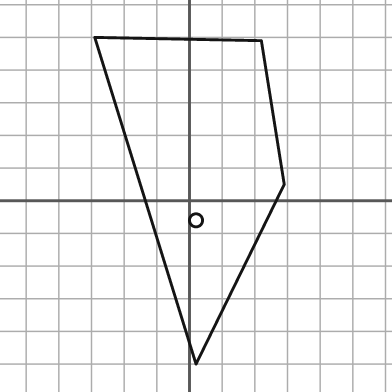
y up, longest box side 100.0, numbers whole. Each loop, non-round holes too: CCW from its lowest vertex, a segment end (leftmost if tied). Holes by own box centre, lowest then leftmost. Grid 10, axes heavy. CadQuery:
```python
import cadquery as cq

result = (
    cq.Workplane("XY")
    .moveTo(2.0, -50.0)
    .lineTo(29.0, 5.0)
    .lineTo(22.0, 49.0)
    .lineTo(-29.0, 50.0)
    .close()
    .moveTo(2.0, -6.0)
    .circle(2.0)
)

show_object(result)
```